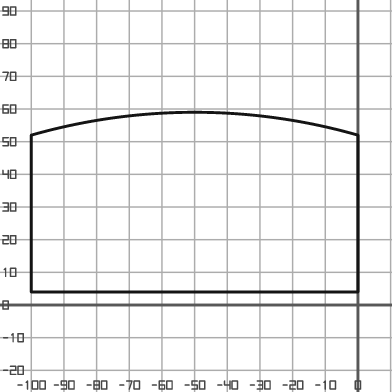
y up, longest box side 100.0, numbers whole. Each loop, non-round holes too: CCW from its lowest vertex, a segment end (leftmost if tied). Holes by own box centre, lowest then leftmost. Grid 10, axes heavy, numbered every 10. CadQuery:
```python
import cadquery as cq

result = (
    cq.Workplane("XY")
    .moveTo(-100.0, 4.0)
    .lineTo(0.0, 4.0)
    .lineTo(0.0, 52.0)
    .threePointArc((-50.0, 59.0), (-100.0, 52.0))
    .close()
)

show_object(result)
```